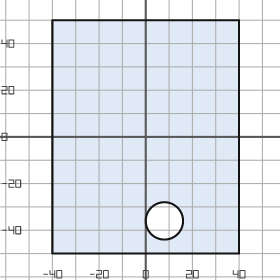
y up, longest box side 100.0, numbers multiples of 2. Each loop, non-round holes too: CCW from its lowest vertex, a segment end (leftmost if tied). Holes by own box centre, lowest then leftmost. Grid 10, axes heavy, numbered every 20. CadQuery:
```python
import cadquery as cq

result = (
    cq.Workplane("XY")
    .moveTo(-40.0, -50.0)
    .lineTo(40.0, -50.0)
    .lineTo(40.0, 50.0)
    .lineTo(-40.0, 50.0)
    .close()
    .moveTo(8.0, -36.0)
    .circle(8.0)
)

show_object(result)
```